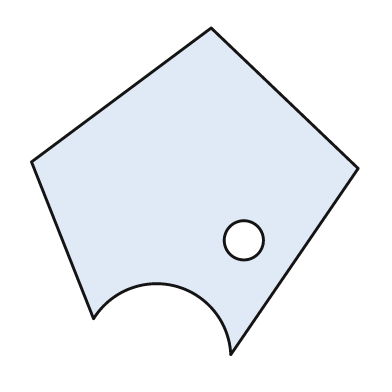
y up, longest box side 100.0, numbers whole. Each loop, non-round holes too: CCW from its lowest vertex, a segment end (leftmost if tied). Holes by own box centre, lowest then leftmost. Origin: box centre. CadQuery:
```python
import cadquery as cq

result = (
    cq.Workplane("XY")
    .moveTo(11.0, -50.0)
    .lineTo(50.0, 7.0)
    .lineTo(5.0, 50.0)
    .lineTo(-50.0, 9.0)
    .lineTo(-31.0, -39.0)
    .threePointArc((-6.0, -29.0), (11.0, -50.0))
    .close()
    .moveTo(15.0, -15.0)
    .circle(6.0)
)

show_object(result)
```